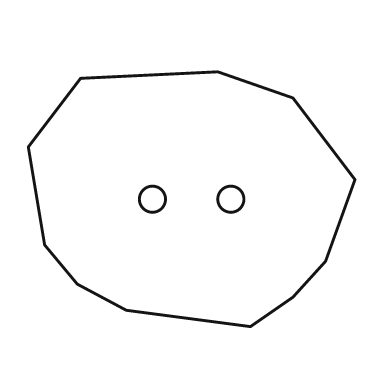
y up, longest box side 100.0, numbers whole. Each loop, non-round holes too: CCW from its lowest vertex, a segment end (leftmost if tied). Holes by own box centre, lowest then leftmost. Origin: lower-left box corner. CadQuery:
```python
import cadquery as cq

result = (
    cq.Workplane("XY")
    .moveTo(68.0, 0.0)
    .lineTo(81.0, 9.0)
    .lineTo(91.0, 20.0)
    .lineTo(100.0, 45.0)
    .lineTo(81.0, 70.0)
    .lineTo(58.0, 78.0)
    .lineTo(16.0, 76.0)
    .lineTo(0.0, 55.0)
    .lineTo(5.0, 25.0)
    .lineTo(15.0, 13.0)
    .lineTo(30.0, 5.0)
    .close()
    .moveTo(38.0, 39.0)
    .circle(4.0)
    .moveTo(62.0, 39.0)
    .circle(4.0)
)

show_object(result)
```